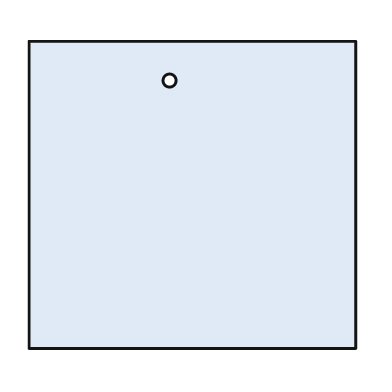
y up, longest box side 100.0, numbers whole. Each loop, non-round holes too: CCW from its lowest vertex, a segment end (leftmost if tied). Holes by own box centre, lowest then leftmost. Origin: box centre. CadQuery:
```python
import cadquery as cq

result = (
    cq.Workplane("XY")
    .moveTo(-50.0, -47.0)
    .lineTo(50.0, -47.0)
    .lineTo(50.0, 47.0)
    .lineTo(-50.0, 47.0)
    .close()
    .moveTo(-7.0, 35.0)
    .circle(2.0)
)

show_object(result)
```